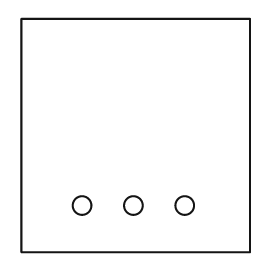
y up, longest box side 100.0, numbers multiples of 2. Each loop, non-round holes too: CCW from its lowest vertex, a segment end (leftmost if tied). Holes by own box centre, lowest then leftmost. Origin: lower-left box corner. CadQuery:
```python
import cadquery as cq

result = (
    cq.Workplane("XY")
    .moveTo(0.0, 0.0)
    .lineTo(98.0, 0.0)
    .lineTo(98.0, 100.0)
    .lineTo(0.0, 100.0)
    .close()
    .moveTo(26.0, 20.0)
    .circle(4.0)
    .moveTo(48.0, 20.0)
    .circle(4.0)
    .moveTo(70.0, 20.0)
    .circle(4.0)
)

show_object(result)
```